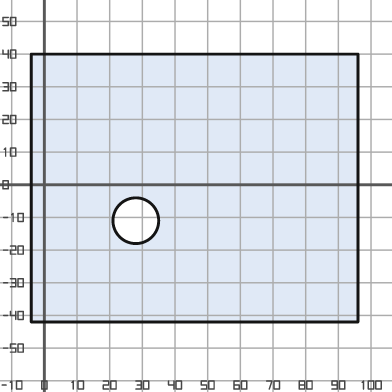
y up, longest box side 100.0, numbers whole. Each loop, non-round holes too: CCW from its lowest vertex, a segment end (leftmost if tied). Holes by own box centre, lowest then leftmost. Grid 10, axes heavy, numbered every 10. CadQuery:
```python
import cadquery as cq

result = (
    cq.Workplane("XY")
    .moveTo(-4.0, -42.0)
    .lineTo(96.0, -42.0)
    .lineTo(96.0, 40.0)
    .lineTo(-4.0, 40.0)
    .close()
    .moveTo(28.0, -11.0)
    .circle(7.0)
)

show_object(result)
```